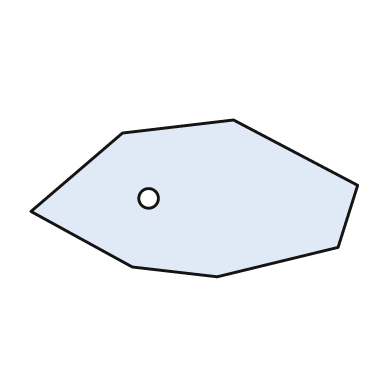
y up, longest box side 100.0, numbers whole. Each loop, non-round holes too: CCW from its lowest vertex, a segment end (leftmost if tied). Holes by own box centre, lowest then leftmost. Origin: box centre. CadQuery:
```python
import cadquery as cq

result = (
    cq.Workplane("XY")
    .moveTo(7.0, -24.0)
    .lineTo(44.0, -15.0)
    .lineTo(50.0, 4.0)
    .lineTo(12.0, 24.0)
    .lineTo(-22.0, 20.0)
    .lineTo(-50.0, -4.0)
    .lineTo(-19.0, -21.0)
    .close()
    .moveTo(-14.0, 0.0)
    .circle(3.0)
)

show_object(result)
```